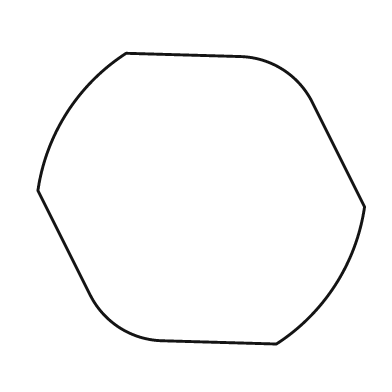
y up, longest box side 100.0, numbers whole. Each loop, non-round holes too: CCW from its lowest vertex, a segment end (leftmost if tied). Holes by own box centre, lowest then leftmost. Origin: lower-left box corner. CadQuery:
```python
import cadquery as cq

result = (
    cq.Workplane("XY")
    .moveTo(73.0, 0.0)
    .threePointArc((91.0, 18.0), (100.0, 42.0))
    .lineTo(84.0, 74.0)
    .threePointArc((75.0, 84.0), (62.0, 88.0))
    .lineTo(27.0, 89.0)
    .threePointArc((9.0, 71.0), (0.0, 47.0))
    .lineTo(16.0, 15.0)
    .threePointArc((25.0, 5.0), (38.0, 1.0))
    .close()
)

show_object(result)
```